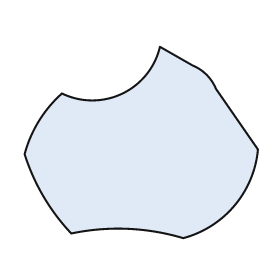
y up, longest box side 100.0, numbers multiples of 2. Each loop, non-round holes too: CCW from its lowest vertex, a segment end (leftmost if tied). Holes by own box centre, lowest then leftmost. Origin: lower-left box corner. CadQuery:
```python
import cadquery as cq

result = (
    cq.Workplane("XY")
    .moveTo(68.0, 0.0)
    .threePointArc((90.0, 14.0), (100.0, 38.0))
    .lineTo(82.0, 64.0)
    .threePointArc((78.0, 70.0), (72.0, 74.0))
    .lineTo(58.0, 82.0)
    .threePointArc((42.0, 62.0), (16.0, 62.0))
    .threePointArc((6.0, 50.0), (0.0, 36.0))
    .threePointArc((8.0, 18.0), (20.0, 2.0))
    .threePointArc((44.0, 4.0), (68.0, 0.0))
    .close()
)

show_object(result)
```